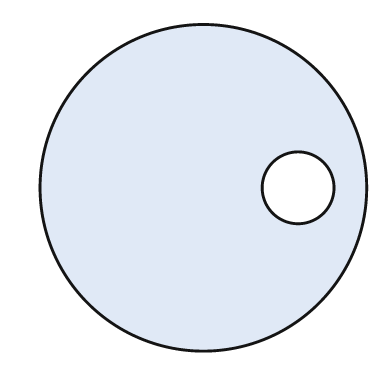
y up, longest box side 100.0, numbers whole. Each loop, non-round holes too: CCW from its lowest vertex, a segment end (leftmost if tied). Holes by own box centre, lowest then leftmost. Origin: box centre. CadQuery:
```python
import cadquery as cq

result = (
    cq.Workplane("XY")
    .moveTo(0.0, 0.0)
    .circle(50.0)
    .moveTo(29.0, 0.0)
    .circle(11.0)
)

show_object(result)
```